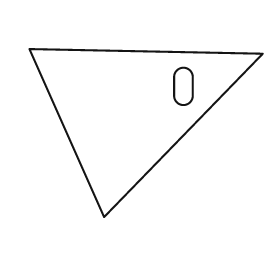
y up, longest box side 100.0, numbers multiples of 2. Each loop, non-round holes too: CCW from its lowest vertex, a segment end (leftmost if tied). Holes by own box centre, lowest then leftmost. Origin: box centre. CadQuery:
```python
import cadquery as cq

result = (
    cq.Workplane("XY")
    .moveTo(-18.0, -36.0)
    .lineTo(50.0, 34.0)
    .lineTo(-50.0, 36.0)
    .close()
    .moveTo(12.0, 16.0)
    .threePointArc((16.0, 12.0), (20.0, 16.0))
    .lineTo(20.0, 24.0)
    .threePointArc((16.0, 28.0), (12.0, 24.0))
    .close()
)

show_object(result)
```